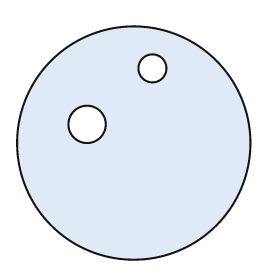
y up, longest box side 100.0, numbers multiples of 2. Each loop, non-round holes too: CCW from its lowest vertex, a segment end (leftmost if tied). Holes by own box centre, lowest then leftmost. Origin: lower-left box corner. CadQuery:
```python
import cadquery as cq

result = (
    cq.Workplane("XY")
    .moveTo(50.0, 50.0)
    .circle(50.0)
    .moveTo(30.0, 58.0)
    .circle(8.0)
    .moveTo(58.0, 82.0)
    .circle(6.0)
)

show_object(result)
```